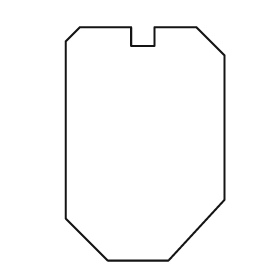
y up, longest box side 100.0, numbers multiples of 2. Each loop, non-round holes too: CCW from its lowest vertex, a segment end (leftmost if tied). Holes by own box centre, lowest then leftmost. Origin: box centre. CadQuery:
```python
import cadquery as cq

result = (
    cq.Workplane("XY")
    .moveTo(-16.0, -50.0)
    .lineTo(10.0, -50.0)
    .lineTo(34.0, -24.0)
    .lineTo(34.0, 38.0)
    .lineTo(22.0, 50.0)
    .lineTo(4.0, 50.0)
    .lineTo(4.0, 42.0)
    .lineTo(-6.0, 42.0)
    .lineTo(-6.0, 50.0)
    .lineTo(-28.0, 50.0)
    .lineTo(-34.0, 44.0)
    .lineTo(-34.0, -32.0)
    .close()
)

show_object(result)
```